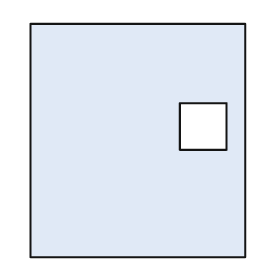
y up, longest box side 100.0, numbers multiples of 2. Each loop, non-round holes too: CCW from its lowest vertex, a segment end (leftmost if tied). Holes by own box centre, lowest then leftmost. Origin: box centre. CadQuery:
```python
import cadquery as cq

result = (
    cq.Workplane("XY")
    .moveTo(-46.0, -50.0)
    .lineTo(46.0, -50.0)
    .lineTo(46.0, 50.0)
    .lineTo(-46.0, 50.0)
    .close()
    .moveTo(18.0, -4.0)
    .lineTo(38.0, -4.0)
    .lineTo(38.0, 16.0)
    .lineTo(18.0, 16.0)
    .close()
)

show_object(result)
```